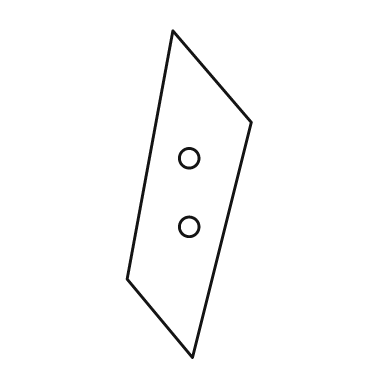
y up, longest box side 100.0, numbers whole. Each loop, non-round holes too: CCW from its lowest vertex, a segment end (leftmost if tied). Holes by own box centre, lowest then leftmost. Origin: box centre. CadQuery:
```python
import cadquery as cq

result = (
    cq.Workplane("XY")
    .moveTo(1.0, -50.0)
    .lineTo(19.0, 22.0)
    .lineTo(-5.0, 50.0)
    .lineTo(-19.0, -26.0)
    .close()
    .moveTo(0.0, -10.0)
    .circle(3.0)
    .moveTo(0.0, 11.0)
    .circle(3.0)
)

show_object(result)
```